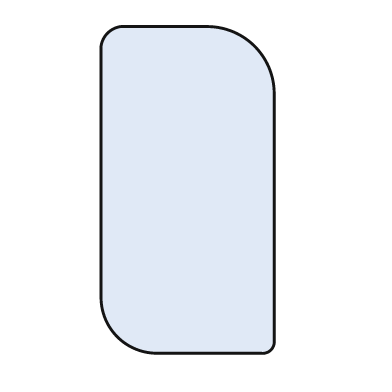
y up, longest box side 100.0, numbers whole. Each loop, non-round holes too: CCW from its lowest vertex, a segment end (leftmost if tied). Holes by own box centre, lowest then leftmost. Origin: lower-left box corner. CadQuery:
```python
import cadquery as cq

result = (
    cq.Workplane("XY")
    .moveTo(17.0, 0.0)
    .lineTo(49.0, 0.0)
    .threePointArc((52.0, 1.0), (53.0, 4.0))
    .lineTo(53.0, 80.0)
    .threePointArc((47.0, 94.0), (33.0, 100.0))
    .lineTo(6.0, 100.0)
    .threePointArc((2.0, 98.0), (0.0, 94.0))
    .lineTo(0.0, 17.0)
    .threePointArc((5.0, 5.0), (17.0, 0.0))
    .close()
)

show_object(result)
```